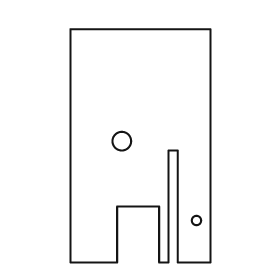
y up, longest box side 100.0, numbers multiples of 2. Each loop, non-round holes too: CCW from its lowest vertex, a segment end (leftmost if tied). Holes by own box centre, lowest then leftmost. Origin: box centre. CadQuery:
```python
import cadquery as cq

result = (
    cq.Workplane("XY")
    .moveTo(-30.0, -50.0)
    .lineTo(-10.0, -50.0)
    .lineTo(-10.0, -26.0)
    .lineTo(8.0, -26.0)
    .lineTo(8.0, -50.0)
    .lineTo(12.0, -50.0)
    .lineTo(12.0, -2.0)
    .lineTo(16.0, -2.0)
    .lineTo(16.0, -50.0)
    .lineTo(30.0, -50.0)
    .lineTo(30.0, 50.0)
    .lineTo(-30.0, 50.0)
    .close()
    .moveTo(24.0, -32.0)
    .circle(2.0)
    .moveTo(-8.0, 2.0)
    .circle(4.0)
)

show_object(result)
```